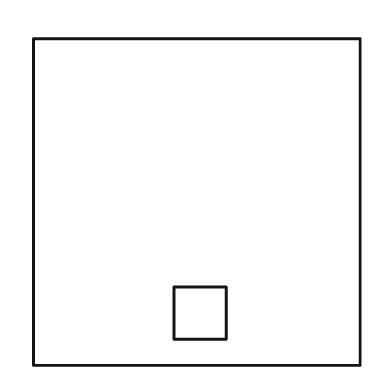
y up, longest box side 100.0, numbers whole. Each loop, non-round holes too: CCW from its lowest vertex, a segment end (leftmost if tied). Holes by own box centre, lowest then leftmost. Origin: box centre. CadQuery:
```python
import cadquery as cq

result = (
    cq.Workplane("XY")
    .moveTo(-50.0, -50.0)
    .lineTo(50.0, -50.0)
    .lineTo(50.0, 50.0)
    .lineTo(-50.0, 50.0)
    .close()
    .moveTo(-7.0, -42.0)
    .lineTo(9.0, -42.0)
    .lineTo(9.0, -26.0)
    .lineTo(-7.0, -26.0)
    .close()
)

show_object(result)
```